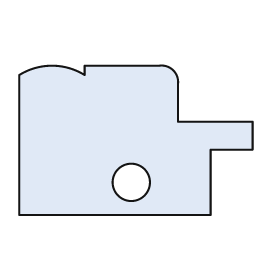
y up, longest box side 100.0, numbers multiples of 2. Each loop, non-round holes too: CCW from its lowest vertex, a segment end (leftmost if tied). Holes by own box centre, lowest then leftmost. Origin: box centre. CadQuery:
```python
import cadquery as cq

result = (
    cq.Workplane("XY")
    .moveTo(-50.0, -32.0)
    .lineTo(32.0, -32.0)
    .lineTo(32.0, -4.0)
    .lineTo(50.0, -4.0)
    .lineTo(50.0, 8.0)
    .lineTo(18.0, 8.0)
    .lineTo(18.0, 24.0)
    .threePointArc((16.0, 30.0), (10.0, 32.0))
    .lineTo(-22.0, 32.0)
    .lineTo(-22.0, 28.0)
    .threePointArc((-36.0, 32.0), (-50.0, 28.0))
    .close()
    .moveTo(-2.0, -18.0)
    .circle(8.0)
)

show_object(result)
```